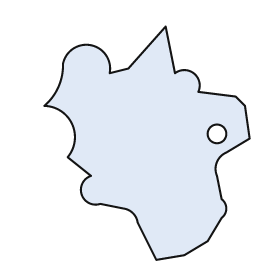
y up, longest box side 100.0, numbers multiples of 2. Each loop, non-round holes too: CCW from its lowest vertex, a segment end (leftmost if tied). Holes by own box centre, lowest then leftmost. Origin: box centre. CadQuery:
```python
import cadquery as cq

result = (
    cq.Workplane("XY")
    .moveTo(4.0, -50.0)
    .lineTo(16.0, -48.0)
    .lineTo(26.0, -42.0)
    .lineTo(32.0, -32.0)
    .threePointArc((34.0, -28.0), (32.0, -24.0))
    .lineTo(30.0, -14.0)
    .threePointArc((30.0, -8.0), (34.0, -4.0))
    .lineTo(44.0, 2.0)
    .lineTo(42.0, 16.0)
    .lineTo(38.0, 20.0)
    .lineTo(22.0, 22.0)
    .threePointArc((20.0, 30.0), (12.0, 30.0))
    .lineTo(8.0, 50.0)
    .lineTo(-8.0, 32.0)
    .lineTo(-16.0, 30.0)
    .threePointArc((-24.0, 42.0), (-36.0, 34.0))
    .threePointArc((-38.0, 24.0), (-44.0, 16.0))
    .threePointArc((-32.0, 8.0), (-34.0, -6.0))
    .lineTo(-24.0, -14.0)
    .threePointArc((-28.0, -22.0), (-20.0, -26.0))
    .lineTo(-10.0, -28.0)
    .threePointArc((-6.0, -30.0), (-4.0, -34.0))
    .close()
    .moveTo(30.0, 4.0)
    .circle(4.0)
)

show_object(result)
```